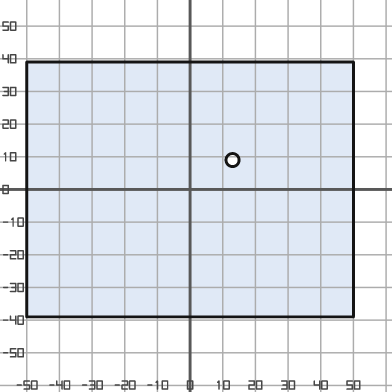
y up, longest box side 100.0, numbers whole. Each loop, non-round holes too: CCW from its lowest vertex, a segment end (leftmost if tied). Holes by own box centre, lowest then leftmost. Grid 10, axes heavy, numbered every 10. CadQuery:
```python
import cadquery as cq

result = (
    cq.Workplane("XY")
    .moveTo(-50.0, -39.0)
    .lineTo(50.0, -39.0)
    .lineTo(50.0, 39.0)
    .lineTo(-50.0, 39.0)
    .close()
    .moveTo(13.0, 9.0)
    .circle(2.0)
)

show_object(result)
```